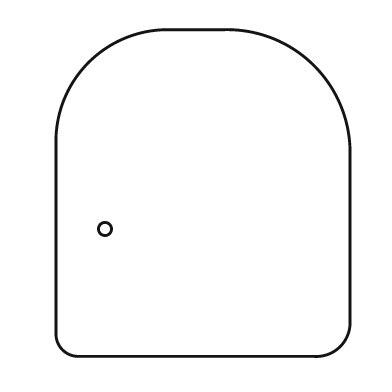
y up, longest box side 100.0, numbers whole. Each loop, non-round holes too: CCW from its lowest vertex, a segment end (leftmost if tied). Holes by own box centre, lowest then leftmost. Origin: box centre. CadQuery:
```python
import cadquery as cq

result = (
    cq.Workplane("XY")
    .moveTo(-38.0, -50.0)
    .lineTo(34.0, -50.0)
    .threePointArc((42.0, -47.0), (45.0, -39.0))
    .lineTo(45.0, 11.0)
    .threePointArc((34.0, 39.0), (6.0, 50.0))
    .lineTo(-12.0, 50.0)
    .threePointArc((-35.0, 40.0), (-45.0, 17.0))
    .lineTo(-45.0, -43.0)
    .threePointArc((-43.0, -48.0), (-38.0, -50.0))
    .close()
    .moveTo(-30.0, -11.0)
    .circle(2.0)
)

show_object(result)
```